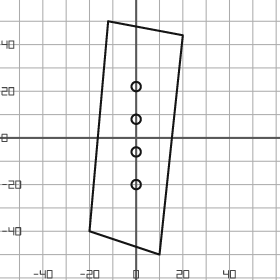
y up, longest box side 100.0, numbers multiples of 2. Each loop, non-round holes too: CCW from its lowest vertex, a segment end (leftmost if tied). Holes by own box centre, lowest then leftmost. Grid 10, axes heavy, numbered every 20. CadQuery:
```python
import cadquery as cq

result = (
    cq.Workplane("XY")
    .moveTo(10.0, -50.0)
    .lineTo(20.0, 44.0)
    .lineTo(-12.0, 50.0)
    .lineTo(-20.0, -40.0)
    .close()
    .moveTo(0.0, -20.0)
    .circle(2.0)
    .moveTo(0.0, -6.0)
    .circle(2.0)
    .moveTo(0.0, 8.0)
    .circle(2.0)
    .moveTo(0.0, 22.0)
    .circle(2.0)
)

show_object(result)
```